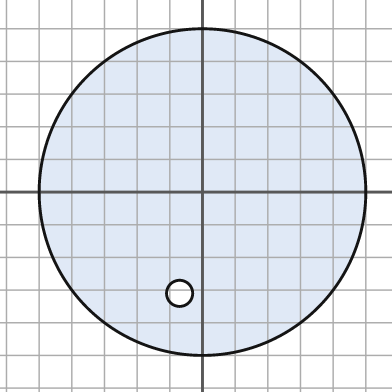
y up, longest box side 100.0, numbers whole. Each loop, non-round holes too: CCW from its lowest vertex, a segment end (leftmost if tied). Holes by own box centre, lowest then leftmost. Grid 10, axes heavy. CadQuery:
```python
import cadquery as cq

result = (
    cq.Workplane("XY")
    .moveTo(0.0, 0.0)
    .circle(50.0)
    .moveTo(-7.0, -31.0)
    .circle(4.0)
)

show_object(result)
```